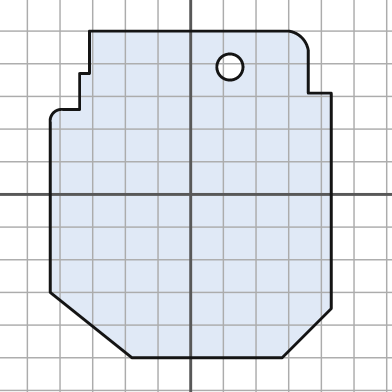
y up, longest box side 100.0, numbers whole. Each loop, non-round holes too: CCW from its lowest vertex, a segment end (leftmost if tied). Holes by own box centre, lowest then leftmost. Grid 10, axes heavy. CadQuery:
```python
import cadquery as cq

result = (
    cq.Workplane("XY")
    .moveTo(-18.0, -50.0)
    .lineTo(28.0, -50.0)
    .lineTo(43.0, -35.0)
    .lineTo(43.0, 31.0)
    .lineTo(36.0, 31.0)
    .lineTo(36.0, 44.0)
    .threePointArc((34.0, 48.0), (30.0, 50.0))
    .lineTo(-31.0, 50.0)
    .lineTo(-31.0, 37.0)
    .lineTo(-34.0, 37.0)
    .lineTo(-34.0, 26.0)
    .lineTo(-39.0, 26.0)
    .threePointArc((-42.0, 25.0), (-43.0, 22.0))
    .lineTo(-43.0, -30.0)
    .close()
    .moveTo(12.0, 39.0)
    .circle(4.0)
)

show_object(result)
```